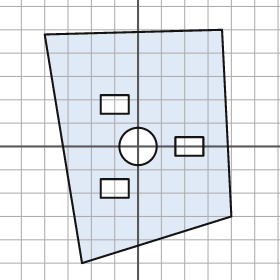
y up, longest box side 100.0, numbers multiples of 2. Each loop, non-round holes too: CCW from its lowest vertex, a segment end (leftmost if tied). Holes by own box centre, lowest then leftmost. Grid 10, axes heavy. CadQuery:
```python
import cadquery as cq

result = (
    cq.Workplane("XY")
    .moveTo(-24.0, -50.0)
    .lineTo(40.0, -30.0)
    .lineTo(36.0, 50.0)
    .lineTo(-40.0, 48.0)
    .close()
    .moveTo(-16.0, -22.0)
    .lineTo(-4.0, -22.0)
    .lineTo(-4.0, -14.0)
    .lineTo(-16.0, -14.0)
    .close()
    .moveTo(0.0, 0.0)
    .circle(8.0)
    .moveTo(16.0, -4.0)
    .lineTo(28.0, -4.0)
    .lineTo(28.0, 4.0)
    .lineTo(16.0, 4.0)
    .close()
    .moveTo(-16.0, 14.0)
    .lineTo(-4.0, 14.0)
    .lineTo(-4.0, 22.0)
    .lineTo(-16.0, 22.0)
    .close()
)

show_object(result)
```